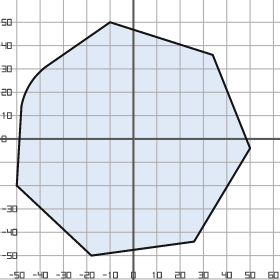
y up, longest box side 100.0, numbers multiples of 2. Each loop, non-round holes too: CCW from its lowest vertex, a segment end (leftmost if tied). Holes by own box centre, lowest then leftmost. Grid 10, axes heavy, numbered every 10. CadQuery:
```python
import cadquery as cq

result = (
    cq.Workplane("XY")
    .moveTo(-18.0, -50.0)
    .lineTo(26.0, -44.0)
    .lineTo(50.0, -4.0)
    .lineTo(34.0, 36.0)
    .lineTo(-10.0, 50.0)
    .lineTo(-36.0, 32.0)
    .threePointArc((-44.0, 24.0), (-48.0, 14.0))
    .lineTo(-50.0, -20.0)
    .close()
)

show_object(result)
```